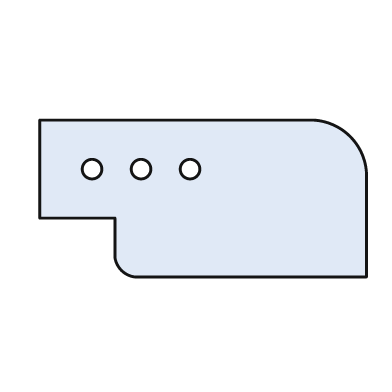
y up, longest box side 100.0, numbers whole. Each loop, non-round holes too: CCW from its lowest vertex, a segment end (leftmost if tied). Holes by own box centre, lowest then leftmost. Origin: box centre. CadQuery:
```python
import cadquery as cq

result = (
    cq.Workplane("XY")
    .moveTo(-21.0, -24.0)
    .lineTo(50.0, -24.0)
    .lineTo(50.0, 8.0)
    .threePointArc((45.0, 19.0), (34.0, 24.0))
    .lineTo(-50.0, 24.0)
    .lineTo(-50.0, -6.0)
    .lineTo(-27.0, -6.0)
    .lineTo(-27.0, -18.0)
    .threePointArc((-25.0, -22.0), (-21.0, -24.0))
    .close()
    .moveTo(-34.0, 9.0)
    .circle(3.0)
    .moveTo(-19.0, 9.0)
    .circle(3.0)
    .moveTo(-4.0, 9.0)
    .circle(3.0)
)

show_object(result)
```